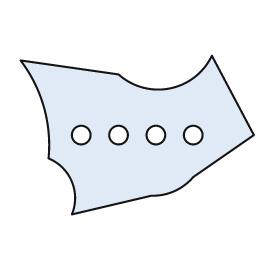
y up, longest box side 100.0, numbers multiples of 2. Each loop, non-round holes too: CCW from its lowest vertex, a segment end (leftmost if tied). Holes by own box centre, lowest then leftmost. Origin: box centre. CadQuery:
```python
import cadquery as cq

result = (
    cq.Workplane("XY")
    .moveTo(-28.0, -34.0)
    .lineTo(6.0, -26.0)
    .threePointArc((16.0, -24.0), (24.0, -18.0))
    .lineTo(50.0, 0.0)
    .lineTo(32.0, 34.0)
    .threePointArc((14.0, 20.0), (-8.0, 26.0))
    .lineTo(-50.0, 32.0)
    .threePointArc((-40.0, 12.0), (-38.0, -10.0))
    .threePointArc((-28.0, -20.0), (-28.0, -34.0))
    .close()
    .moveTo(-24.0, 0.0)
    .circle(4.0)
    .moveTo(-8.0, 0.0)
    .circle(4.0)
    .moveTo(8.0, 0.0)
    .circle(4.0)
    .moveTo(24.0, 0.0)
    .circle(4.0)
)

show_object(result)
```